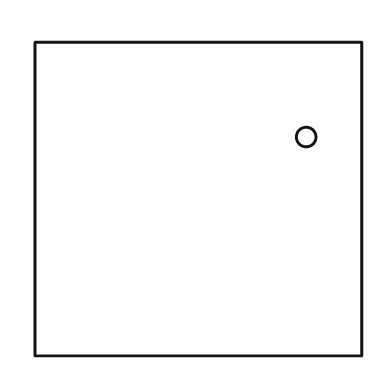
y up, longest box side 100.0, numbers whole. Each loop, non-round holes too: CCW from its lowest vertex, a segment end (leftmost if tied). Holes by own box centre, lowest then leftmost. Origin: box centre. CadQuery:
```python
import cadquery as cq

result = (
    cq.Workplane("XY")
    .moveTo(-50.0, -48.0)
    .lineTo(50.0, -48.0)
    .lineTo(50.0, 48.0)
    .lineTo(-50.0, 48.0)
    .close()
    .moveTo(33.0, 19.0)
    .circle(3.0)
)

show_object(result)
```